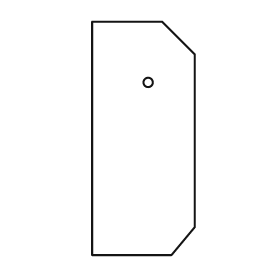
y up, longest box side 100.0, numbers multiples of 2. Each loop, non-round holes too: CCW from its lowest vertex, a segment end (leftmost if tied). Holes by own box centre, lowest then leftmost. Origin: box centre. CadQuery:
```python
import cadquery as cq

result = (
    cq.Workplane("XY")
    .moveTo(-22.0, -50.0)
    .lineTo(12.0, -50.0)
    .lineTo(22.0, -38.0)
    .lineTo(22.0, 36.0)
    .lineTo(8.0, 50.0)
    .lineTo(-22.0, 50.0)
    .close()
    .moveTo(2.0, 24.0)
    .circle(2.0)
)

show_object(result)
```